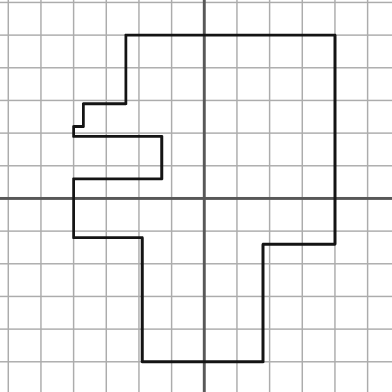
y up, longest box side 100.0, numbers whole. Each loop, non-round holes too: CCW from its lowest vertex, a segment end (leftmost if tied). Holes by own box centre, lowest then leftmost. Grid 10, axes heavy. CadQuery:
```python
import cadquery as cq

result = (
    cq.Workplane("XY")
    .moveTo(-19.0, -50.0)
    .lineTo(18.0, -50.0)
    .lineTo(18.0, -14.0)
    .lineTo(40.0, -14.0)
    .lineTo(40.0, 50.0)
    .lineTo(-24.0, 50.0)
    .lineTo(-24.0, 29.0)
    .lineTo(-37.0, 29.0)
    .lineTo(-37.0, 22.0)
    .lineTo(-40.0, 22.0)
    .lineTo(-40.0, 19.0)
    .lineTo(-13.0, 19.0)
    .lineTo(-13.0, 6.0)
    .lineTo(-40.0, 6.0)
    .lineTo(-40.0, -12.0)
    .lineTo(-19.0, -12.0)
    .close()
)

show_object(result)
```